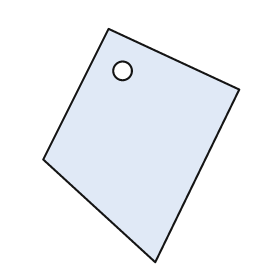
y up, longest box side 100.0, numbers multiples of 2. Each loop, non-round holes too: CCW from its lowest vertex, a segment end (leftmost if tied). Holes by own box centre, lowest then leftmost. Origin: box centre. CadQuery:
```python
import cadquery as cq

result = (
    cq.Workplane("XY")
    .moveTo(6.0, -50.0)
    .lineTo(42.0, 24.0)
    .lineTo(-14.0, 50.0)
    .lineTo(-42.0, -6.0)
    .close()
    .moveTo(-8.0, 32.0)
    .circle(4.0)
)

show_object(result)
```